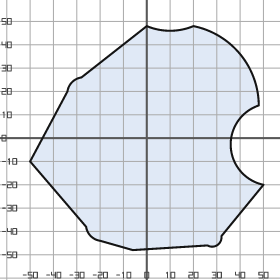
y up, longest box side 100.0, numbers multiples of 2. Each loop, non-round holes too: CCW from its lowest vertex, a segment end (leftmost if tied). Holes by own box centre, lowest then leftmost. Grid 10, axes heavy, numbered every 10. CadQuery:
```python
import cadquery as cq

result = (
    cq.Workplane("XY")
    .moveTo(-6.0, -48.0)
    .lineTo(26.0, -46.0)
    .threePointArc((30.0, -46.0), (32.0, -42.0))
    .lineTo(50.0, -20.0)
    .threePointArc((36.0, -4.0), (48.0, 14.0))
    .threePointArc((40.0, 36.0), (20.0, 48.0))
    .threePointArc((10.0, 46.0), (0.0, 48.0))
    .lineTo(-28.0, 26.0)
    .threePointArc((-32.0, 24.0), (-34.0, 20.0))
    .lineTo(-50.0, -10.0)
    .lineTo(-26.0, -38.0)
    .threePointArc((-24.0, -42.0), (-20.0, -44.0))
    .close()
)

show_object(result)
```